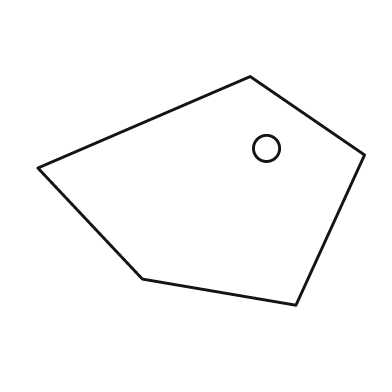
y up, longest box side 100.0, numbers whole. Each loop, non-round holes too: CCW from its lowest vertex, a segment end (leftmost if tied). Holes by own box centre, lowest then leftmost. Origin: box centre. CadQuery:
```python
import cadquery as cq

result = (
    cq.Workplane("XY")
    .moveTo(29.0, -35.0)
    .lineTo(50.0, 11.0)
    .lineTo(15.0, 35.0)
    .lineTo(-50.0, 7.0)
    .lineTo(-18.0, -27.0)
    .close()
    .moveTo(20.0, 13.0)
    .circle(4.0)
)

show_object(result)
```